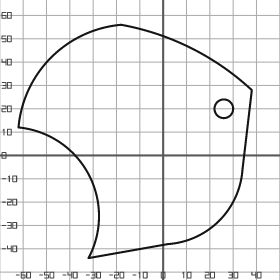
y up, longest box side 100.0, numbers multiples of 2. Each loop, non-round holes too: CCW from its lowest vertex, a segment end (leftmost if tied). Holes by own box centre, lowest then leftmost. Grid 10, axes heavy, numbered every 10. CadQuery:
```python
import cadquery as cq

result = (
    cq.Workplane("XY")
    .moveTo(-32.0, -44.0)
    .lineTo(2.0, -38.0)
    .threePointArc((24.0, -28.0), (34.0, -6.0))
    .lineTo(38.0, 28.0)
    .threePointArc((12.0, 46.0), (-18.0, 56.0))
    .threePointArc((-48.0, 42.0), (-62.0, 12.0))
    .threePointArc((-32.0, -8.0), (-32.0, -44.0))
    .close()
    .moveTo(26.0, 20.0)
    .circle(4.0)
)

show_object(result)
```